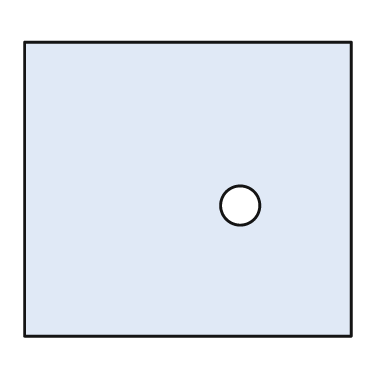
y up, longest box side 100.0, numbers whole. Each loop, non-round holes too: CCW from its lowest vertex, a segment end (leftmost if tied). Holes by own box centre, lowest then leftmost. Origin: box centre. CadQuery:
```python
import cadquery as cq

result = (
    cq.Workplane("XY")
    .moveTo(-50.0, -45.0)
    .lineTo(50.0, -45.0)
    .lineTo(50.0, 45.0)
    .lineTo(-50.0, 45.0)
    .close()
    .moveTo(16.0, -5.0)
    .circle(6.0)
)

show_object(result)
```